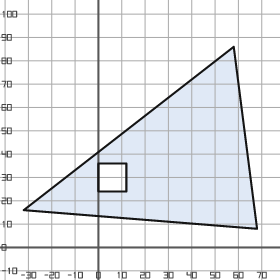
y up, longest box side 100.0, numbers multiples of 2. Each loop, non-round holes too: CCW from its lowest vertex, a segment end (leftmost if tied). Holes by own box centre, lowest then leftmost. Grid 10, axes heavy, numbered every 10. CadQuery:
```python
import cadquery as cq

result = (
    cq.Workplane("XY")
    .moveTo(68.0, 8.0)
    .lineTo(58.0, 86.0)
    .lineTo(-32.0, 16.0)
    .close()
    .moveTo(0.0, 24.0)
    .lineTo(12.0, 24.0)
    .lineTo(12.0, 36.0)
    .lineTo(0.0, 36.0)
    .close()
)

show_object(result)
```